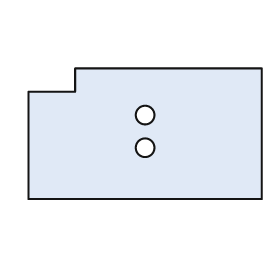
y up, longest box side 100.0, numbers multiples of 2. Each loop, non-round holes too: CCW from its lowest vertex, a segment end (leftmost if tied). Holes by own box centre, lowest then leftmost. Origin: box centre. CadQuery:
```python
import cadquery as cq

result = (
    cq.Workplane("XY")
    .moveTo(-50.0, -28.0)
    .lineTo(50.0, -28.0)
    .lineTo(50.0, 28.0)
    .lineTo(-30.0, 28.0)
    .lineTo(-30.0, 18.0)
    .lineTo(-50.0, 18.0)
    .close()
    .moveTo(0.0, -6.0)
    .circle(4.0)
    .moveTo(0.0, 8.0)
    .circle(4.0)
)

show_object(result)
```